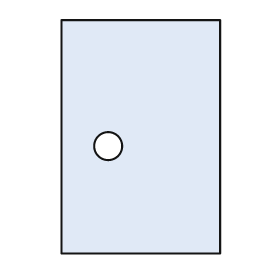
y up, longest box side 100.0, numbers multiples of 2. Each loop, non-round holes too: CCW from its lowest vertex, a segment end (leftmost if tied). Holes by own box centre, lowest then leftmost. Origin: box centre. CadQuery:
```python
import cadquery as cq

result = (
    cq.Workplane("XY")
    .moveTo(-34.0, -50.0)
    .lineTo(34.0, -50.0)
    .lineTo(34.0, 50.0)
    .lineTo(-34.0, 50.0)
    .close()
    .moveTo(-14.0, -4.0)
    .circle(6.0)
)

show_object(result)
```